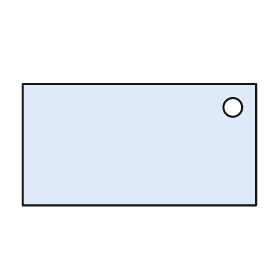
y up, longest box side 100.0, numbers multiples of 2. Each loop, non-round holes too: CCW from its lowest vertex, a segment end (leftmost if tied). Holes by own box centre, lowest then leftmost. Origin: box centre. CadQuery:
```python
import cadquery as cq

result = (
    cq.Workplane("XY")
    .moveTo(-50.0, -26.0)
    .lineTo(50.0, -26.0)
    .lineTo(50.0, 26.0)
    .lineTo(-50.0, 26.0)
    .close()
    .moveTo(40.0, 16.0)
    .circle(4.0)
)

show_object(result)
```